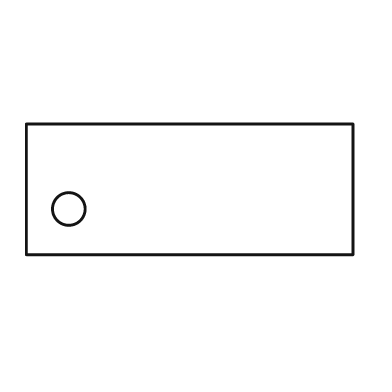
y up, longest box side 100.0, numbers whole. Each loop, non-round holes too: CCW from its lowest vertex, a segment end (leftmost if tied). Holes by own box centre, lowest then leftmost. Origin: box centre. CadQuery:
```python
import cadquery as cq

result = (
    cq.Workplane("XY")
    .moveTo(-50.0, -20.0)
    .lineTo(50.0, -20.0)
    .lineTo(50.0, 20.0)
    .lineTo(-50.0, 20.0)
    .close()
    .moveTo(-37.0, -6.0)
    .circle(5.0)
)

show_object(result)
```